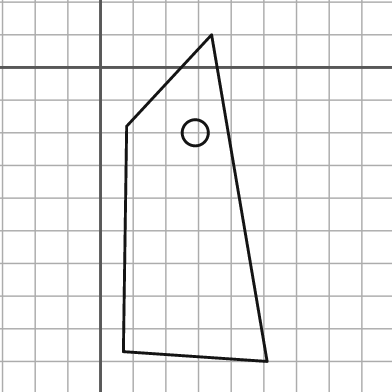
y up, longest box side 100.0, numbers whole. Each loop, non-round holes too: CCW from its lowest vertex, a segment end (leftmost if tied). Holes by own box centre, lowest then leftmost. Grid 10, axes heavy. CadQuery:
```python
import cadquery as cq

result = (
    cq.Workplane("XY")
    .moveTo(51.0, -90.0)
    .lineTo(34.0, 10.0)
    .lineTo(8.0, -18.0)
    .lineTo(7.0, -87.0)
    .close()
    .moveTo(29.0, -20.0)
    .circle(4.0)
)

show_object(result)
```